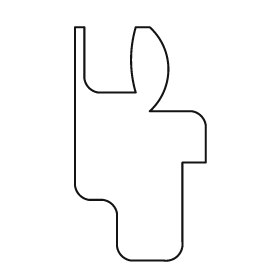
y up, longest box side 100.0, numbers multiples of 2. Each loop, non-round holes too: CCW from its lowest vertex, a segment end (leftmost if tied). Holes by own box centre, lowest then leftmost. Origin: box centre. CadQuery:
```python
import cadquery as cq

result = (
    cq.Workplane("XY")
    .moveTo(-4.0, -50.0)
    .lineTo(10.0, -50.0)
    .threePointArc((16.0, -48.0), (18.0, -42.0))
    .lineTo(18.0, -8.0)
    .lineTo(28.0, -8.0)
    .lineTo(28.0, 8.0)
    .threePointArc((26.0, 12.0), (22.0, 14.0))
    .lineTo(4.0, 14.0)
    .threePointArc((12.0, 32.0), (4.0, 50.0))
    .lineTo(-2.0, 50.0)
    .threePointArc((-4.0, 36.0), (-2.0, 22.0))
    .lineTo(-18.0, 22.0)
    .threePointArc((-22.0, 24.0), (-24.0, 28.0))
    .lineTo(-24.0, 50.0)
    .lineTo(-28.0, 50.0)
    .lineTo(-28.0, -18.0)
    .threePointArc((-26.0, -22.0), (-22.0, -24.0))
    .lineTo(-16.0, -24.0)
    .threePointArc((-12.0, -26.0), (-10.0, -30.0))
    .lineTo(-10.0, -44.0)
    .threePointArc((-8.0, -48.0), (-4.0, -50.0))
    .close()
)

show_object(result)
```